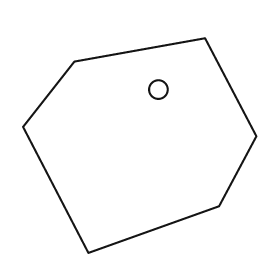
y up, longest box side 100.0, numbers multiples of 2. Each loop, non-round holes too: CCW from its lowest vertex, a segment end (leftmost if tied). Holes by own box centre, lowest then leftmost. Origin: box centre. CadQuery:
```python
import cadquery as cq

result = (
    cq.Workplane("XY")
    .moveTo(-22.0, -46.0)
    .lineTo(34.0, -26.0)
    .lineTo(50.0, 4.0)
    .lineTo(28.0, 46.0)
    .lineTo(-28.0, 36.0)
    .lineTo(-50.0, 8.0)
    .close()
    .moveTo(8.0, 24.0)
    .circle(4.0)
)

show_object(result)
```